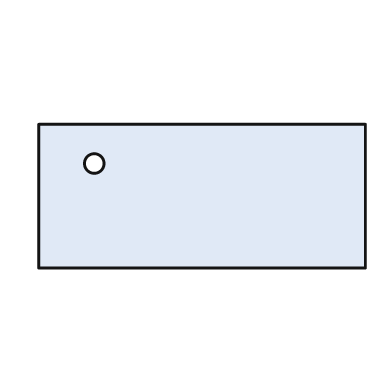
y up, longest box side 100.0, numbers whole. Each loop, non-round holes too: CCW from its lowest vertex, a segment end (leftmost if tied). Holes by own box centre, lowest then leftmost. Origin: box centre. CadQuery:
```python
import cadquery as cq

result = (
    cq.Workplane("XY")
    .moveTo(-50.0, -22.0)
    .lineTo(50.0, -22.0)
    .lineTo(50.0, 22.0)
    .lineTo(-50.0, 22.0)
    .close()
    .moveTo(-33.0, 10.0)
    .circle(3.0)
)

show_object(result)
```